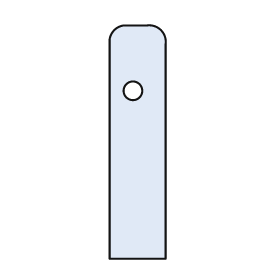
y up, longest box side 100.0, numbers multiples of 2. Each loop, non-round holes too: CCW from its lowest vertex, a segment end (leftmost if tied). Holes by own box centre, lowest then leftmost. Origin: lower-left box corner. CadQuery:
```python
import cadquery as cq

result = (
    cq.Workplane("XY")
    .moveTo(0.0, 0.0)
    .lineTo(24.0, 0.0)
    .lineTo(24.0, 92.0)
    .threePointArc((22.0, 98.0), (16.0, 100.0))
    .lineTo(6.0, 100.0)
    .threePointArc((2.0, 98.0), (0.0, 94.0))
    .close()
    .moveTo(10.0, 72.0)
    .circle(4.0)
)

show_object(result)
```